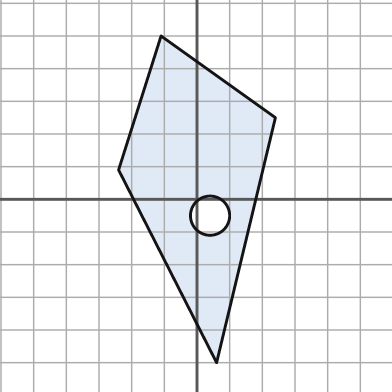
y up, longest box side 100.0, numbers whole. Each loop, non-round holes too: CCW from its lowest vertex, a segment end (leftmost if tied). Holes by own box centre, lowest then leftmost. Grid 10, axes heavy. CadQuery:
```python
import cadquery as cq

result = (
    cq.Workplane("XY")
    .moveTo(6.0, -50.0)
    .lineTo(24.0, 25.0)
    .lineTo(-11.0, 50.0)
    .lineTo(-24.0, 9.0)
    .close()
    .moveTo(4.0, -5.0)
    .circle(6.0)
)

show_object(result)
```